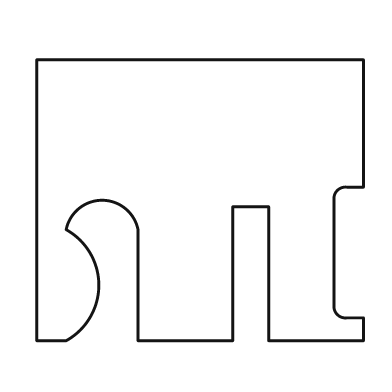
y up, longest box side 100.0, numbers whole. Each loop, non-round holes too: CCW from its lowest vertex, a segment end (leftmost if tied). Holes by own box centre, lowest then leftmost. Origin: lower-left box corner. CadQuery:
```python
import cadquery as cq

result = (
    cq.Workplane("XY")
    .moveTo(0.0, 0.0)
    .lineTo(9.0, 0.0)
    .threePointArc((19.0, 17.0), (9.0, 34.0))
    .threePointArc((20.0, 43.0), (31.0, 34.0))
    .lineTo(31.0, 0.0)
    .lineTo(60.0, 0.0)
    .lineTo(60.0, 41.0)
    .lineTo(71.0, 41.0)
    .lineTo(71.0, 0.0)
    .lineTo(100.0, 0.0)
    .lineTo(100.0, 7.0)
    .lineTo(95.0, 7.0)
    .threePointArc((92.0, 8.0), (91.0, 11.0))
    .lineTo(91.0, 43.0)
    .threePointArc((92.0, 46.0), (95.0, 47.0))
    .lineTo(100.0, 47.0)
    .lineTo(100.0, 86.0)
    .lineTo(0.0, 86.0)
    .close()
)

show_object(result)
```